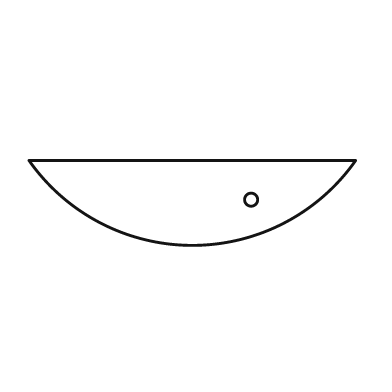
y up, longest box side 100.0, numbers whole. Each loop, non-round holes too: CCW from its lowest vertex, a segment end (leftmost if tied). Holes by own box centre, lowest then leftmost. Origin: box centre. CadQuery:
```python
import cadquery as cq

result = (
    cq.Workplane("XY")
    .moveTo(-50.0, 13.0)
    .threePointArc((0.0, -13.0), (50.0, 13.0))
    .close()
    .moveTo(18.0, 1.0)
    .circle(2.0)
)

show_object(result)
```